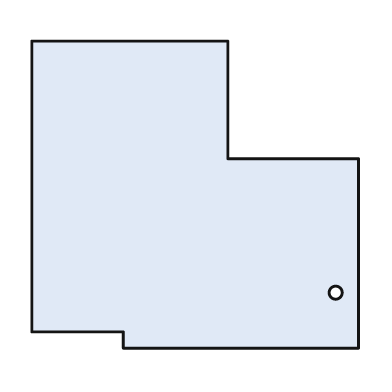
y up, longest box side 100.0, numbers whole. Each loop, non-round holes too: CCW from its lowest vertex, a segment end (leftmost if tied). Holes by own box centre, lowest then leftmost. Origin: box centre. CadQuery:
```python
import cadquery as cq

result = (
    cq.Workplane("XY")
    .moveTo(-22.0, -47.0)
    .lineTo(50.0, -47.0)
    .lineTo(50.0, 11.0)
    .lineTo(10.0, 11.0)
    .lineTo(10.0, 47.0)
    .lineTo(-50.0, 47.0)
    .lineTo(-50.0, -42.0)
    .lineTo(-22.0, -42.0)
    .close()
    .moveTo(43.0, -30.0)
    .circle(2.0)
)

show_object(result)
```